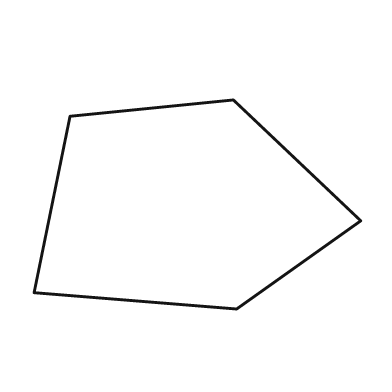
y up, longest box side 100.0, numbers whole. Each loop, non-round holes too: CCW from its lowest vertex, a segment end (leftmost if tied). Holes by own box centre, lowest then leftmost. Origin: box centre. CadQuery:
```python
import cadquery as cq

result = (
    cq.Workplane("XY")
    .moveTo(12.0, -32.0)
    .lineTo(50.0, -5.0)
    .lineTo(11.0, 32.0)
    .lineTo(-39.0, 27.0)
    .lineTo(-50.0, -27.0)
    .close()
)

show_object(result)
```